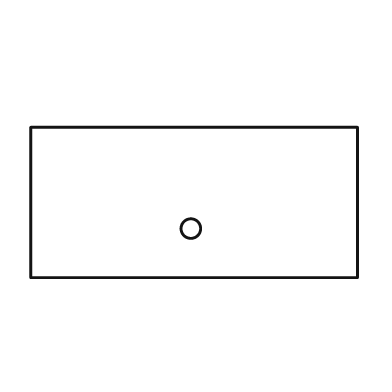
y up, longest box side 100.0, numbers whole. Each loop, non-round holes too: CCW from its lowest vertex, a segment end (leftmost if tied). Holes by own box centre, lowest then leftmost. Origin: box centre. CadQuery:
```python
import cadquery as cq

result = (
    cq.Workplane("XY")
    .moveTo(-50.0, -23.0)
    .lineTo(50.0, -23.0)
    .lineTo(50.0, 23.0)
    .lineTo(-50.0, 23.0)
    .close()
    .moveTo(-1.0, -8.0)
    .circle(3.0)
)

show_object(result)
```